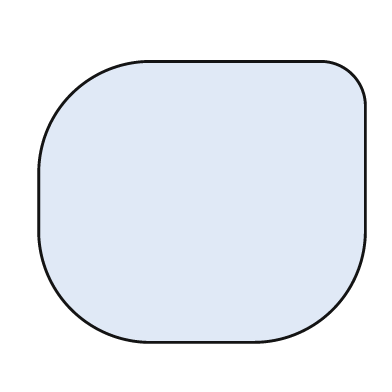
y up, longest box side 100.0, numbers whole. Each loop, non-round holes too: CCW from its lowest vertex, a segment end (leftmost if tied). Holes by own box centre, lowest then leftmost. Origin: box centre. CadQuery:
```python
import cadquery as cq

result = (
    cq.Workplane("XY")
    .moveTo(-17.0, -43.0)
    .lineTo(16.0, -43.0)
    .threePointArc((40.0, -33.0), (50.0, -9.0))
    .lineTo(50.0, 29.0)
    .threePointArc((46.0, 39.0), (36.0, 43.0))
    .lineTo(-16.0, 43.0)
    .threePointArc((-40.0, 33.0), (-50.0, 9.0))
    .lineTo(-50.0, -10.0)
    .threePointArc((-40.0, -33.0), (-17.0, -43.0))
    .close()
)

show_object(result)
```